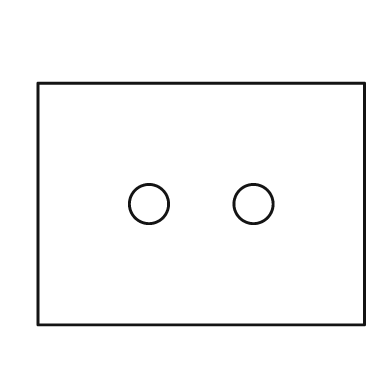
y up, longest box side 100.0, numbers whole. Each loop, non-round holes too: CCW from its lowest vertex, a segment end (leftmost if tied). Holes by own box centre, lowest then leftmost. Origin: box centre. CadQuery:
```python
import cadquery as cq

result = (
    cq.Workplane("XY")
    .moveTo(-50.0, -37.0)
    .lineTo(50.0, -37.0)
    .lineTo(50.0, 37.0)
    .lineTo(-50.0, 37.0)
    .close()
    .moveTo(-16.0, 0.0)
    .circle(6.0)
    .moveTo(16.0, 0.0)
    .circle(6.0)
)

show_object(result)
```